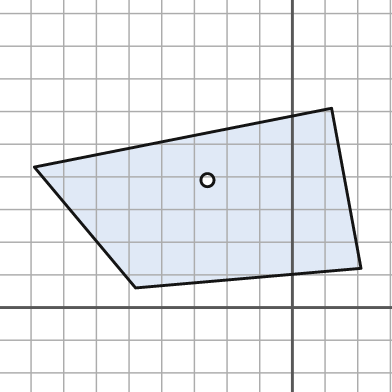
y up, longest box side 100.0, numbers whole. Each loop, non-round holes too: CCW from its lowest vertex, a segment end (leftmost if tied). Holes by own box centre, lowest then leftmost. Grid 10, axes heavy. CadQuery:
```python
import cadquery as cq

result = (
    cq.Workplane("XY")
    .moveTo(-48.0, 6.0)
    .lineTo(21.0, 12.0)
    .lineTo(12.0, 61.0)
    .lineTo(-79.0, 43.0)
    .close()
    .moveTo(-26.0, 39.0)
    .circle(2.0)
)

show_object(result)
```